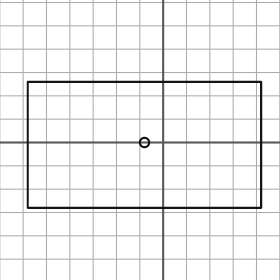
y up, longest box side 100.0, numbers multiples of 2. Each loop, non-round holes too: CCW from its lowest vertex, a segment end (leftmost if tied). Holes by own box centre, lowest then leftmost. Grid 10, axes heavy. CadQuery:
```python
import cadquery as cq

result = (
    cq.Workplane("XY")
    .moveTo(-58.0, -28.0)
    .lineTo(42.0, -28.0)
    .lineTo(42.0, 26.0)
    .lineTo(-58.0, 26.0)
    .close()
    .moveTo(-8.0, 0.0)
    .circle(2.0)
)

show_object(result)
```